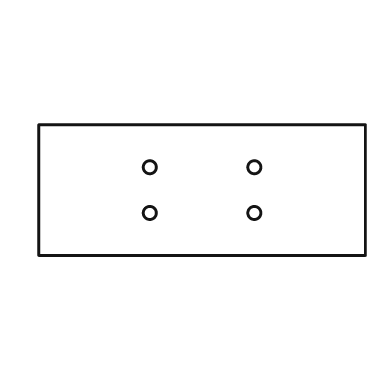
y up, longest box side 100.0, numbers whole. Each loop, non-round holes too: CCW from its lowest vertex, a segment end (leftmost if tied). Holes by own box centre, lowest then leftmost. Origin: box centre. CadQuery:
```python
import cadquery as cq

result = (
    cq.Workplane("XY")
    .moveTo(-50.0, -20.0)
    .lineTo(50.0, -20.0)
    .lineTo(50.0, 20.0)
    .lineTo(-50.0, 20.0)
    .close()
    .moveTo(-16.0, -7.0)
    .circle(2.0)
    .moveTo(16.0, -7.0)
    .circle(2.0)
    .moveTo(-16.0, 7.0)
    .circle(2.0)
    .moveTo(16.0, 7.0)
    .circle(2.0)
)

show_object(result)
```